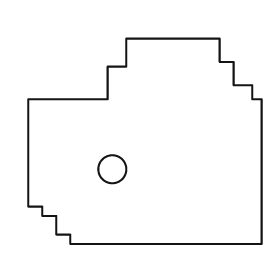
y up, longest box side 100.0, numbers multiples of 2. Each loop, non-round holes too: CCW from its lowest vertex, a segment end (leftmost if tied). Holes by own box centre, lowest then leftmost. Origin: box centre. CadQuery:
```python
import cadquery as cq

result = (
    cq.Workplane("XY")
    .moveTo(-32.0, -44.0)
    .lineTo(50.0, -44.0)
    .lineTo(50.0, 18.0)
    .lineTo(46.0, 18.0)
    .lineTo(46.0, 24.0)
    .lineTo(38.0, 24.0)
    .lineTo(38.0, 34.0)
    .lineTo(32.0, 34.0)
    .lineTo(32.0, 44.0)
    .lineTo(-8.0, 44.0)
    .lineTo(-8.0, 32.0)
    .lineTo(-16.0, 32.0)
    .lineTo(-16.0, 18.0)
    .lineTo(-50.0, 18.0)
    .lineTo(-50.0, -28.0)
    .lineTo(-44.0, -28.0)
    .lineTo(-44.0, -32.0)
    .lineTo(-38.0, -32.0)
    .lineTo(-38.0, -40.0)
    .lineTo(-32.0, -40.0)
    .close()
    .moveTo(-14.0, -12.0)
    .circle(6.0)
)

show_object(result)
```